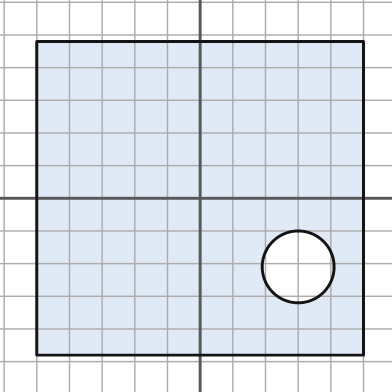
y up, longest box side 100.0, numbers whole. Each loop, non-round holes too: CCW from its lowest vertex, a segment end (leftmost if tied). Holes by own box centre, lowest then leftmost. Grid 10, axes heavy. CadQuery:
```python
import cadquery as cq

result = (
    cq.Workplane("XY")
    .moveTo(-50.0, -48.0)
    .lineTo(50.0, -48.0)
    .lineTo(50.0, 48.0)
    .lineTo(-50.0, 48.0)
    .close()
    .moveTo(30.0, -21.0)
    .circle(11.0)
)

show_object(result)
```